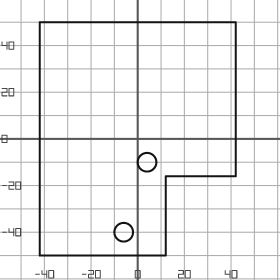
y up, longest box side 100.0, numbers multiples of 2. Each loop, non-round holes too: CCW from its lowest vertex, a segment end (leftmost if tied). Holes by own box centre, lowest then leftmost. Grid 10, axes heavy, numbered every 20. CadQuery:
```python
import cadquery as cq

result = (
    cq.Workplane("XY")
    .moveTo(-42.0, -50.0)
    .lineTo(12.0, -50.0)
    .lineTo(12.0, -16.0)
    .lineTo(42.0, -16.0)
    .lineTo(42.0, 50.0)
    .lineTo(-42.0, 50.0)
    .close()
    .moveTo(-6.0, -40.0)
    .circle(4.0)
    .moveTo(4.0, -10.0)
    .circle(4.0)
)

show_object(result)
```